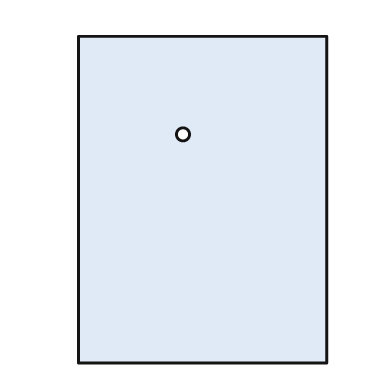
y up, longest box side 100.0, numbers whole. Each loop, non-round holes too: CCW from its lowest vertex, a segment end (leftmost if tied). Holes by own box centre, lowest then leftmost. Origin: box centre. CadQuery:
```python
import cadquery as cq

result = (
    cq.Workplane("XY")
    .moveTo(-38.0, -50.0)
    .lineTo(38.0, -50.0)
    .lineTo(38.0, 50.0)
    .lineTo(-38.0, 50.0)
    .close()
    .moveTo(-6.0, 20.0)
    .circle(2.0)
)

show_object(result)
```